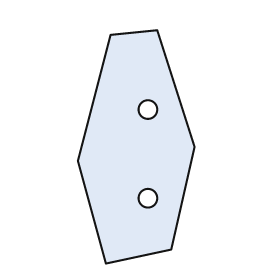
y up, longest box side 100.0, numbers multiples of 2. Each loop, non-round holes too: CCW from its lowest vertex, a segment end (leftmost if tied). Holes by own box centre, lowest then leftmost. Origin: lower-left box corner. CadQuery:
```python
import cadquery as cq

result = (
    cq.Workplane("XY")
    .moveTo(12.0, 0.0)
    .lineTo(40.0, 6.0)
    .lineTo(50.0, 50.0)
    .lineTo(34.0, 100.0)
    .lineTo(14.0, 98.0)
    .lineTo(0.0, 44.0)
    .close()
    .moveTo(30.0, 28.0)
    .circle(4.0)
    .moveTo(30.0, 66.0)
    .circle(4.0)
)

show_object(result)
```